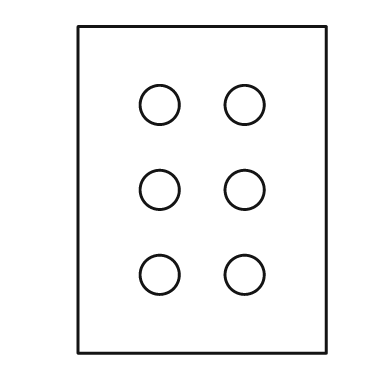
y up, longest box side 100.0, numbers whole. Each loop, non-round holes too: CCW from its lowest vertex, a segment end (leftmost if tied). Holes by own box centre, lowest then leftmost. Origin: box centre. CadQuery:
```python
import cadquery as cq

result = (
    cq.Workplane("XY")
    .moveTo(-38.0, -50.0)
    .lineTo(38.0, -50.0)
    .lineTo(38.0, 50.0)
    .lineTo(-38.0, 50.0)
    .close()
    .moveTo(-13.0, -26.0)
    .circle(6.0)
    .moveTo(13.0, -26.0)
    .circle(6.0)
    .moveTo(-13.0, 0.0)
    .circle(6.0)
    .moveTo(13.0, 0.0)
    .circle(6.0)
    .moveTo(-13.0, 26.0)
    .circle(6.0)
    .moveTo(13.0, 26.0)
    .circle(6.0)
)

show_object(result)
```